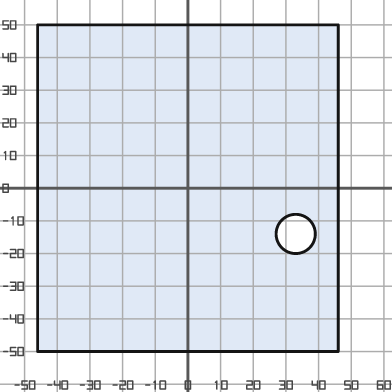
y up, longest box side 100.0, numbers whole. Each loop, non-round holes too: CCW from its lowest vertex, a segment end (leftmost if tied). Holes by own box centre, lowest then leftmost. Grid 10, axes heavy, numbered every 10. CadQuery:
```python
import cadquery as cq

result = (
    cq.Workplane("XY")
    .moveTo(-46.0, -50.0)
    .lineTo(46.0, -50.0)
    .lineTo(46.0, 50.0)
    .lineTo(-46.0, 50.0)
    .close()
    .moveTo(33.0, -14.0)
    .circle(6.0)
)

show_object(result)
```